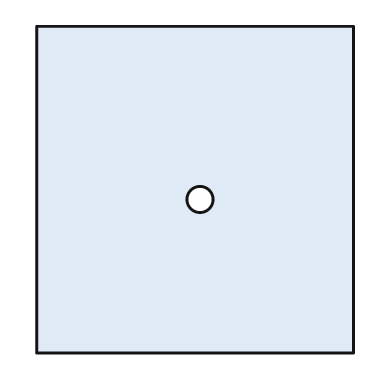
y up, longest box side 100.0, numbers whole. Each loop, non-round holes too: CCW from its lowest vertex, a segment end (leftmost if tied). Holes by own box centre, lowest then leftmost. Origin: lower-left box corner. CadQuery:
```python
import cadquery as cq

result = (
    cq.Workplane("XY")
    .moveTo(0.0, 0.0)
    .lineTo(97.0, 0.0)
    .lineTo(97.0, 100.0)
    .lineTo(0.0, 100.0)
    .close()
    .moveTo(50.0, 47.0)
    .circle(4.0)
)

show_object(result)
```